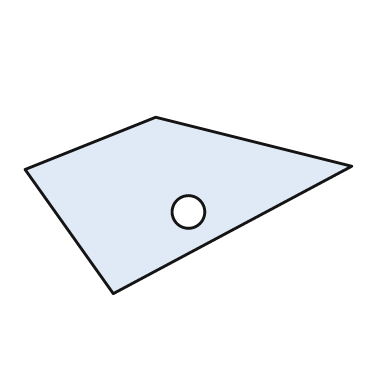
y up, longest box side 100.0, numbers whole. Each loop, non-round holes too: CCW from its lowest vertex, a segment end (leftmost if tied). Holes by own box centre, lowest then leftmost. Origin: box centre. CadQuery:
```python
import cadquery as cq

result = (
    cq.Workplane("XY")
    .moveTo(-23.0, -27.0)
    .lineTo(50.0, 12.0)
    .lineTo(-10.0, 27.0)
    .lineTo(-50.0, 11.0)
    .close()
    .moveTo(0.0, -2.0)
    .circle(5.0)
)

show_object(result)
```